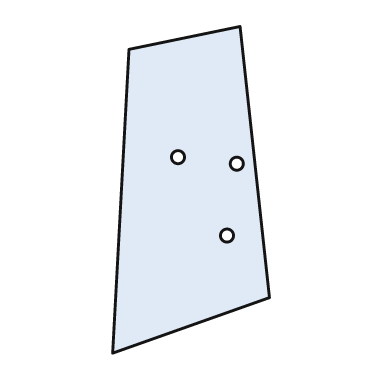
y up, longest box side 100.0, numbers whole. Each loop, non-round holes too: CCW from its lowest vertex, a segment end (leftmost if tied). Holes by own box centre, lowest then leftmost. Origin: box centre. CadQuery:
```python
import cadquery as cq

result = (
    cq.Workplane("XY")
    .moveTo(-24.0, -50.0)
    .lineTo(24.0, -33.0)
    .lineTo(15.0, 50.0)
    .lineTo(-19.0, 43.0)
    .close()
    .moveTo(11.0, -14.0)
    .circle(2.0)
    .moveTo(14.0, 8.0)
    .circle(2.0)
    .moveTo(-4.0, 10.0)
    .circle(2.0)
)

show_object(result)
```